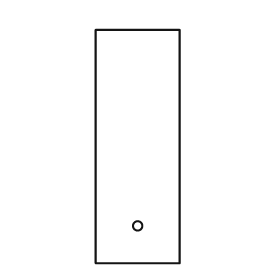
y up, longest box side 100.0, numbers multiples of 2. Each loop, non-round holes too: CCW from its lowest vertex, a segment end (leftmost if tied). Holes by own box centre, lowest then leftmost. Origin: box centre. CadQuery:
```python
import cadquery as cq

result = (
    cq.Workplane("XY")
    .moveTo(-18.0, -50.0)
    .lineTo(18.0, -50.0)
    .lineTo(18.0, 50.0)
    .lineTo(-18.0, 50.0)
    .close()
    .moveTo(0.0, -34.0)
    .circle(2.0)
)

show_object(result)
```